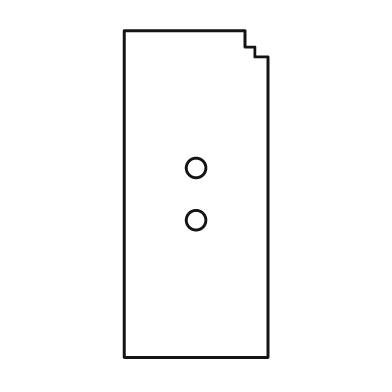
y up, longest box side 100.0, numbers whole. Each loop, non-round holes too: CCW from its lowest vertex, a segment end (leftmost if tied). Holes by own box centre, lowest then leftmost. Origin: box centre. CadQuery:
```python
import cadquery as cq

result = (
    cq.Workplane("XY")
    .moveTo(-22.0, -50.0)
    .lineTo(22.0, -50.0)
    .lineTo(22.0, 42.0)
    .lineTo(18.0, 42.0)
    .lineTo(18.0, 45.0)
    .lineTo(15.0, 45.0)
    .lineTo(15.0, 50.0)
    .lineTo(-22.0, 50.0)
    .close()
    .moveTo(0.0, -8.0)
    .circle(3.0)
    .moveTo(0.0, 8.0)
    .circle(3.0)
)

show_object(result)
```